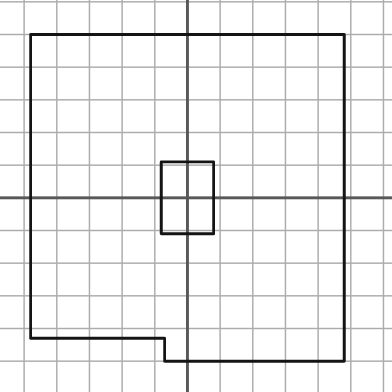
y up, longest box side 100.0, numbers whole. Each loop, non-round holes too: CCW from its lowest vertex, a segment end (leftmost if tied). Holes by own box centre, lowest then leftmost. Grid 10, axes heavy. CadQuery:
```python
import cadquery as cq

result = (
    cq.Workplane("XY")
    .moveTo(-7.0, -50.0)
    .lineTo(48.0, -50.0)
    .lineTo(48.0, 50.0)
    .lineTo(-48.0, 50.0)
    .lineTo(-48.0, -43.0)
    .lineTo(-7.0, -43.0)
    .close()
    .moveTo(-8.0, -11.0)
    .lineTo(8.0, -11.0)
    .lineTo(8.0, 11.0)
    .lineTo(-8.0, 11.0)
    .close()
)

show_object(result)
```